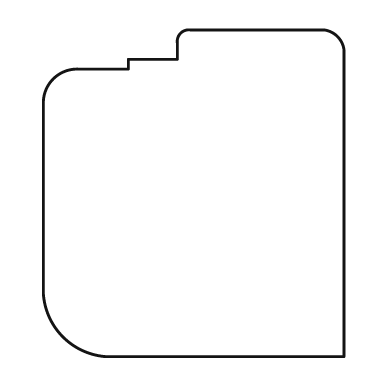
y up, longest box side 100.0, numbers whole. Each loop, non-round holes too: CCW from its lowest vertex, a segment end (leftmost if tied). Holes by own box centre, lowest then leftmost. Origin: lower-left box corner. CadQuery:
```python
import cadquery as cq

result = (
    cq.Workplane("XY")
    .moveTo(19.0, 0.0)
    .lineTo(92.0, 0.0)
    .lineTo(92.0, 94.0)
    .threePointArc((90.0, 98.0), (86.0, 100.0))
    .lineTo(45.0, 100.0)
    .threePointArc((42.0, 99.0), (41.0, 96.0))
    .lineTo(41.0, 91.0)
    .lineTo(26.0, 91.0)
    .lineTo(26.0, 88.0)
    .lineTo(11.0, 88.0)
    .threePointArc((3.0, 85.0), (0.0, 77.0))
    .lineTo(0.0, 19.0)
    .threePointArc((6.0, 6.0), (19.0, 0.0))
    .close()
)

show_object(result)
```